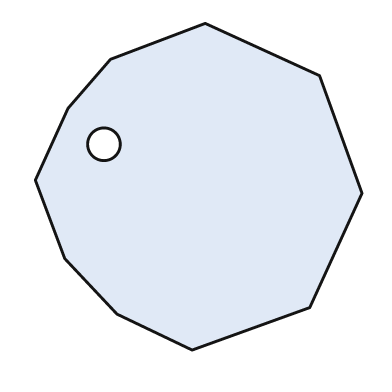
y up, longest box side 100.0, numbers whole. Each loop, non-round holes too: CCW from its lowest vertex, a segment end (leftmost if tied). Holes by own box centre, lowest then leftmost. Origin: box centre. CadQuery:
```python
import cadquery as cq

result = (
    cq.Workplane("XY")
    .moveTo(-2.0, -50.0)
    .lineTo(34.0, -37.0)
    .lineTo(50.0, -2.0)
    .lineTo(37.0, 34.0)
    .lineTo(2.0, 50.0)
    .lineTo(-27.0, 39.0)
    .lineTo(-40.0, 24.0)
    .lineTo(-50.0, 2.0)
    .lineTo(-41.0, -22.0)
    .lineTo(-25.0, -39.0)
    .close()
    .moveTo(-29.0, 13.0)
    .circle(5.0)
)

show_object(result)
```